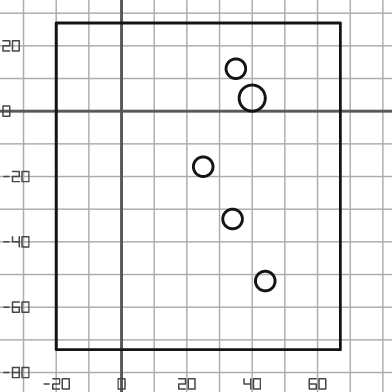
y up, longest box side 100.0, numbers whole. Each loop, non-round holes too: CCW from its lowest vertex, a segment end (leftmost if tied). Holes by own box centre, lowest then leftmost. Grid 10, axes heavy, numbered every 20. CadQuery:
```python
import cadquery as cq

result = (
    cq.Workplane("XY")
    .moveTo(-20.0, -73.0)
    .lineTo(67.0, -73.0)
    .lineTo(67.0, 27.0)
    .lineTo(-20.0, 27.0)
    .close()
    .moveTo(44.0, -52.0)
    .circle(3.0)
    .moveTo(34.0, -33.0)
    .circle(3.0)
    .moveTo(25.0, -17.0)
    .circle(3.0)
    .moveTo(40.0, 4.0)
    .circle(4.0)
    .moveTo(35.0, 13.0)
    .circle(3.0)
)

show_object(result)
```